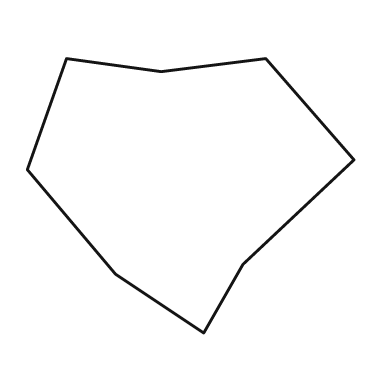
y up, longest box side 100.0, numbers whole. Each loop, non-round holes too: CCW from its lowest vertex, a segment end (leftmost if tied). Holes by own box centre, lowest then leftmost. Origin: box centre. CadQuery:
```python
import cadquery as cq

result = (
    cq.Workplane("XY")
    .moveTo(4.0, -42.0)
    .lineTo(16.0, -21.0)
    .lineTo(50.0, 11.0)
    .lineTo(23.0, 42.0)
    .lineTo(-9.0, 38.0)
    .lineTo(-38.0, 42.0)
    .lineTo(-50.0, 8.0)
    .lineTo(-23.0, -24.0)
    .close()
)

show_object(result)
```